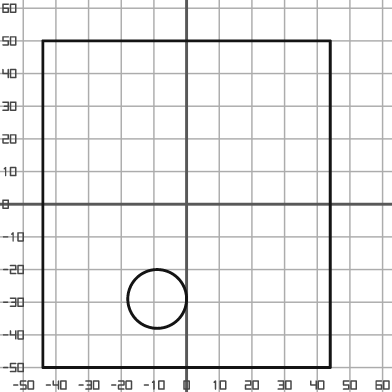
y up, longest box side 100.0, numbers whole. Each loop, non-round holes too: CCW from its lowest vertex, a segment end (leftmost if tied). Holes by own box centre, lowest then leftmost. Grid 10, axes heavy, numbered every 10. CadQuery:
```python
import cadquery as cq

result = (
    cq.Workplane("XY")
    .moveTo(-44.0, -50.0)
    .lineTo(44.0, -50.0)
    .lineTo(44.0, 50.0)
    .lineTo(-44.0, 50.0)
    .close()
    .moveTo(-9.0, -29.0)
    .circle(9.0)
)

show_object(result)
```